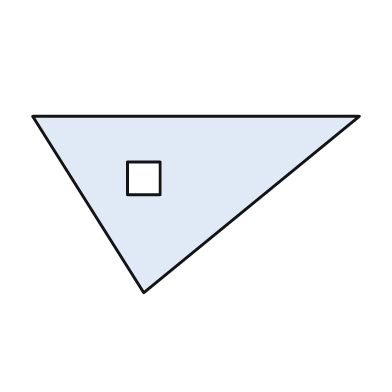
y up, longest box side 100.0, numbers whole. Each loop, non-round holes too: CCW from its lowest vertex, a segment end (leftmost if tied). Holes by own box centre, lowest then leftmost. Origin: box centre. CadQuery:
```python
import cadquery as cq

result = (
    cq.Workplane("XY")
    .moveTo(-16.0, -27.0)
    .lineTo(50.0, 27.0)
    .lineTo(-50.0, 27.0)
    .close()
    .moveTo(-21.0, 3.0)
    .lineTo(-11.0, 3.0)
    .lineTo(-11.0, 13.0)
    .lineTo(-21.0, 13.0)
    .close()
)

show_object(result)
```